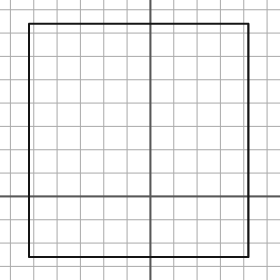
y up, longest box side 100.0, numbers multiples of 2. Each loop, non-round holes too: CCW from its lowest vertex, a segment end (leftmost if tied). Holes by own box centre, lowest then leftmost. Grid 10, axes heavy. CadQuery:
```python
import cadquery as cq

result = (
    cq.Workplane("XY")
    .moveTo(-52.0, -26.0)
    .lineTo(42.0, -26.0)
    .lineTo(42.0, 74.0)
    .lineTo(-52.0, 74.0)
    .close()
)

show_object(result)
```